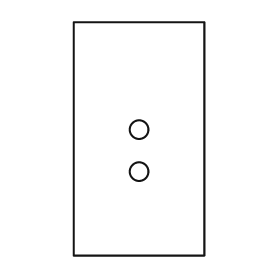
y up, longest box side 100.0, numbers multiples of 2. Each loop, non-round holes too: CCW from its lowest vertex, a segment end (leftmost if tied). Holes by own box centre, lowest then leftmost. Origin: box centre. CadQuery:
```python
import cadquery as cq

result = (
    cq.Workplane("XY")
    .moveTo(-28.0, -50.0)
    .lineTo(28.0, -50.0)
    .lineTo(28.0, 50.0)
    .lineTo(-28.0, 50.0)
    .close()
    .moveTo(0.0, -14.0)
    .circle(4.0)
    .moveTo(0.0, 4.0)
    .circle(4.0)
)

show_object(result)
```